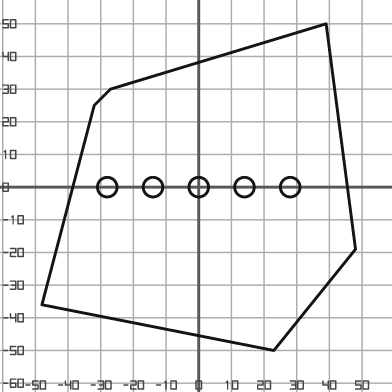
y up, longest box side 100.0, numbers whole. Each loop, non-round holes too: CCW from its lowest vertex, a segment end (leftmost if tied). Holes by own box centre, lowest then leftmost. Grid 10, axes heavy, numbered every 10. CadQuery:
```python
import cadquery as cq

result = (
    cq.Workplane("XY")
    .moveTo(23.0, -50.0)
    .lineTo(48.0, -19.0)
    .lineTo(39.0, 50.0)
    .lineTo(-27.0, 30.0)
    .lineTo(-32.0, 25.0)
    .lineTo(-48.0, -36.0)
    .close()
    .moveTo(-28.0, 0.0)
    .circle(3.0)
    .moveTo(-14.0, 0.0)
    .circle(3.0)
    .moveTo(0.0, 0.0)
    .circle(3.0)
    .moveTo(14.0, 0.0)
    .circle(3.0)
    .moveTo(28.0, 0.0)
    .circle(3.0)
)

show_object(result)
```